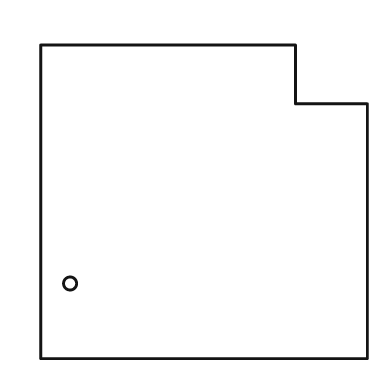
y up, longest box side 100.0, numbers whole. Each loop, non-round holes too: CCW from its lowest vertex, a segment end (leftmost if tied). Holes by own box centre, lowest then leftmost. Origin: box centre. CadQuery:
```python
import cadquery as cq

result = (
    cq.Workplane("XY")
    .moveTo(-50.0, -48.0)
    .lineTo(50.0, -48.0)
    .lineTo(50.0, 30.0)
    .lineTo(28.0, 30.0)
    .lineTo(28.0, 48.0)
    .lineTo(-50.0, 48.0)
    .close()
    .moveTo(-41.0, -25.0)
    .circle(2.0)
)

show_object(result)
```